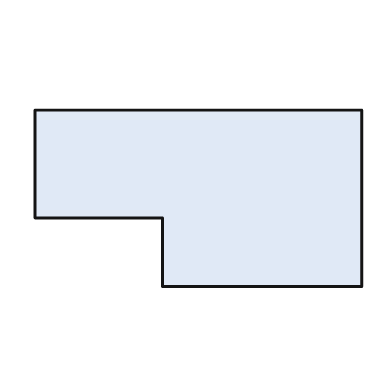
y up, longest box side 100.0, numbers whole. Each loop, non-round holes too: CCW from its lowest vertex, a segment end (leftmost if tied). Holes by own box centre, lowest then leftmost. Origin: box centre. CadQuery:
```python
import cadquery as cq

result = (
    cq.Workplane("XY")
    .moveTo(-11.0, -27.0)
    .lineTo(50.0, -27.0)
    .lineTo(50.0, 27.0)
    .lineTo(-50.0, 27.0)
    .lineTo(-50.0, -6.0)
    .lineTo(-11.0, -6.0)
    .close()
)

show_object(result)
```